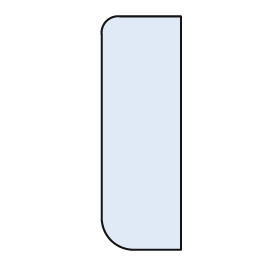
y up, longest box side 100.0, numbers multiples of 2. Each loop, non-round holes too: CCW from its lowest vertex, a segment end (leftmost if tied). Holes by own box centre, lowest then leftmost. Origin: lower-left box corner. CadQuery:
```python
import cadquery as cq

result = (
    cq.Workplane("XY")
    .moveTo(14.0, 0.0)
    .lineTo(34.0, 0.0)
    .lineTo(34.0, 100.0)
    .lineTo(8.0, 100.0)
    .threePointArc((2.0, 98.0), (0.0, 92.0))
    .lineTo(0.0, 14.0)
    .threePointArc((4.0, 4.0), (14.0, 0.0))
    .close()
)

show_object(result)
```